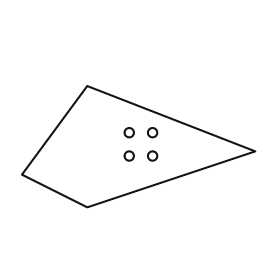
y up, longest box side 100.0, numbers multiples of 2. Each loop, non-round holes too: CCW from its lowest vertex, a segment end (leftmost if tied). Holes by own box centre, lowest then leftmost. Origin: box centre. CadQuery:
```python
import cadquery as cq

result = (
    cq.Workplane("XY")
    .moveTo(-22.0, -26.0)
    .lineTo(50.0, -2.0)
    .lineTo(-22.0, 26.0)
    .lineTo(-50.0, -12.0)
    .close()
    .moveTo(-4.0, -4.0)
    .circle(2.0)
    .moveTo(6.0, -4.0)
    .circle(2.0)
    .moveTo(-4.0, 6.0)
    .circle(2.0)
    .moveTo(6.0, 6.0)
    .circle(2.0)
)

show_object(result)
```